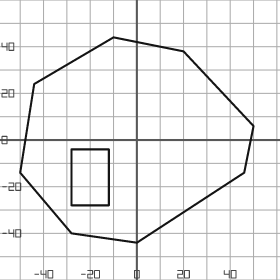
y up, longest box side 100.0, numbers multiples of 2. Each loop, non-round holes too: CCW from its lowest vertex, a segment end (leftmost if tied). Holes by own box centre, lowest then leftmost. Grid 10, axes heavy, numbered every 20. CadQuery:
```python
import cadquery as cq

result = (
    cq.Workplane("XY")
    .moveTo(0.0, -44.0)
    .lineTo(46.0, -14.0)
    .lineTo(50.0, 6.0)
    .lineTo(20.0, 38.0)
    .lineTo(-10.0, 44.0)
    .lineTo(-44.0, 24.0)
    .lineTo(-50.0, -14.0)
    .lineTo(-28.0, -40.0)
    .close()
    .moveTo(-28.0, -28.0)
    .lineTo(-12.0, -28.0)
    .lineTo(-12.0, -4.0)
    .lineTo(-28.0, -4.0)
    .close()
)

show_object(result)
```